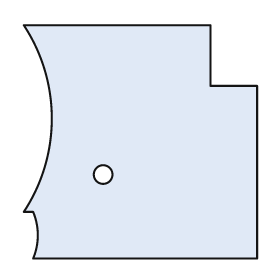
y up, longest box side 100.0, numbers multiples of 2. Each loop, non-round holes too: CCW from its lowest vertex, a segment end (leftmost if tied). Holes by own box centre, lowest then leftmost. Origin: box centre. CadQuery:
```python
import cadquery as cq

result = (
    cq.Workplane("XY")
    .moveTo(-46.0, -50.0)
    .lineTo(50.0, -50.0)
    .lineTo(50.0, 24.0)
    .lineTo(30.0, 24.0)
    .lineTo(30.0, 50.0)
    .lineTo(-50.0, 50.0)
    .threePointArc((-38.0, 10.0), (-50.0, -30.0))
    .lineTo(-46.0, -30.0)
    .threePointArc((-44.0, -40.0), (-46.0, -50.0))
    .close()
    .moveTo(-16.0, -14.0)
    .circle(4.0)
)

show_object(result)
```